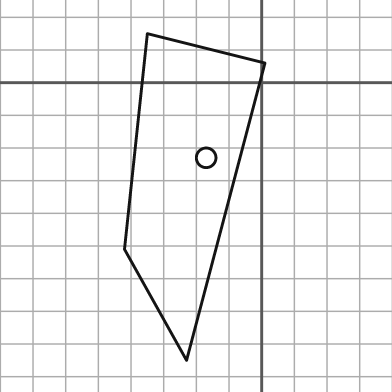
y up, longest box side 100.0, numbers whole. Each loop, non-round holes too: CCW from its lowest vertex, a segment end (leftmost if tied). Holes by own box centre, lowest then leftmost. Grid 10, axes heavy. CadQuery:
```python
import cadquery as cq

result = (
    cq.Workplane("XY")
    .moveTo(-23.0, -85.0)
    .lineTo(1.0, 6.0)
    .lineTo(-35.0, 15.0)
    .lineTo(-42.0, -51.0)
    .close()
    .moveTo(-17.0, -23.0)
    .circle(3.0)
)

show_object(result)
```